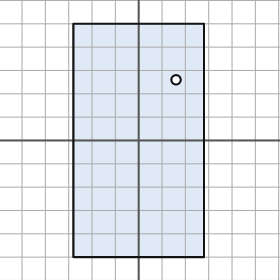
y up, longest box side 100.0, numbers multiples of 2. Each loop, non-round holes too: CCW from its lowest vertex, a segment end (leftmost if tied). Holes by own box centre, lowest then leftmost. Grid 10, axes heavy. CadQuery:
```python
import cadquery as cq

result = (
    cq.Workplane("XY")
    .moveTo(-28.0, -50.0)
    .lineTo(28.0, -50.0)
    .lineTo(28.0, 50.0)
    .lineTo(-28.0, 50.0)
    .close()
    .moveTo(16.0, 26.0)
    .circle(2.0)
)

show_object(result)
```